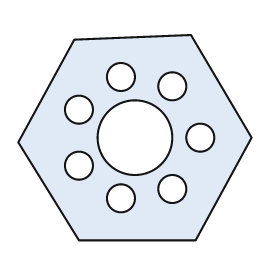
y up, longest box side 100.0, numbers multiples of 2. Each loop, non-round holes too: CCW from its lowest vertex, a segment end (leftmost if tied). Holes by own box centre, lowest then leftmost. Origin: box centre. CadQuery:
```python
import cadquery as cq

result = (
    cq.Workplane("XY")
    .moveTo(-24.0, -44.0)
    .lineTo(26.0, -44.0)
    .lineTo(50.0, 0.0)
    .lineTo(24.0, 44.0)
    .lineTo(-26.0, 42.0)
    .lineTo(-50.0, -2.0)
    .close()
    .moveTo(-6.0, -26.0)
    .circle(6.0)
    .moveTo(16.0, -22.0)
    .circle(6.0)
    .moveTo(-24.0, -12.0)
    .circle(6.0)
    .moveTo(0.0, 0.0)
    .circle(16.0)
    .moveTo(28.0, 0.0)
    .circle(6.0)
    .moveTo(-24.0, 12.0)
    .circle(6.0)
    .moveTo(16.0, 22.0)
    .circle(6.0)
    .moveTo(-6.0, 26.0)
    .circle(6.0)
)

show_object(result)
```